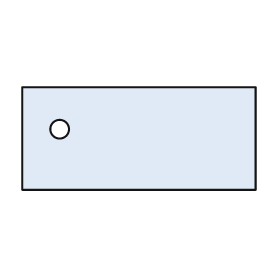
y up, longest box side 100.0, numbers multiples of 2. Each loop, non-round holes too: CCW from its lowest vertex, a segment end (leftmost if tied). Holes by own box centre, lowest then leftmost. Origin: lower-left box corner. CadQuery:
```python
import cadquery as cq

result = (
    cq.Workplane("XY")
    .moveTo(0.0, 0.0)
    .lineTo(100.0, 0.0)
    .lineTo(100.0, 44.0)
    .lineTo(0.0, 44.0)
    .close()
    .moveTo(16.0, 26.0)
    .circle(4.0)
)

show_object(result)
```